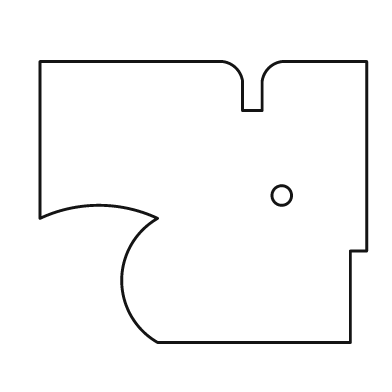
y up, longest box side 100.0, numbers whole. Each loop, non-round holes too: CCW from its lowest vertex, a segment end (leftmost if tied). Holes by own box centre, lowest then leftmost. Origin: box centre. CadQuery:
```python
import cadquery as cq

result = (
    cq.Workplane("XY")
    .moveTo(-14.0, -43.0)
    .lineTo(45.0, -43.0)
    .lineTo(45.0, -15.0)
    .lineTo(50.0, -15.0)
    .lineTo(50.0, 43.0)
    .lineTo(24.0, 43.0)
    .threePointArc((20.0, 41.0), (18.0, 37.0))
    .lineTo(18.0, 28.0)
    .lineTo(12.0, 28.0)
    .lineTo(12.0, 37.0)
    .threePointArc((10.0, 41.0), (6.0, 43.0))
    .lineTo(-50.0, 43.0)
    .lineTo(-50.0, -5.0)
    .threePointArc((-32.0, -1.0), (-14.0, -5.0))
    .threePointArc((-25.0, -24.0), (-14.0, -43.0))
    .close()
    .moveTo(24.0, 2.0)
    .circle(3.0)
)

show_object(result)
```